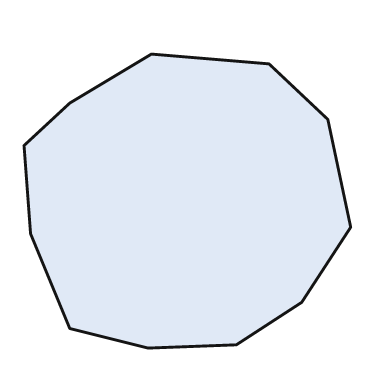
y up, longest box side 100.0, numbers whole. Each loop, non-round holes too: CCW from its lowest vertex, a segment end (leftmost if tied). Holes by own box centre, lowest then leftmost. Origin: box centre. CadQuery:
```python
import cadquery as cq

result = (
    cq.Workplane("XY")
    .moveTo(-12.0, -45.0)
    .lineTo(15.0, -44.0)
    .lineTo(35.0, -31.0)
    .lineTo(50.0, -8.0)
    .lineTo(43.0, 25.0)
    .lineTo(25.0, 42.0)
    .lineTo(-11.0, 45.0)
    .lineTo(-36.0, 30.0)
    .lineTo(-50.0, 17.0)
    .lineTo(-48.0, -10.0)
    .lineTo(-36.0, -39.0)
    .close()
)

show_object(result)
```